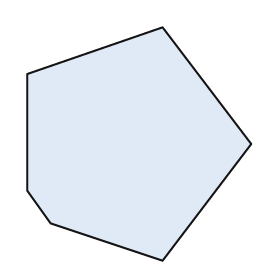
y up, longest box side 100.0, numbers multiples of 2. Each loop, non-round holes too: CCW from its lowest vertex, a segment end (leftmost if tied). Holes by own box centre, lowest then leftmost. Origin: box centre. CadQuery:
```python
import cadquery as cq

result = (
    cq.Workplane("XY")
    .moveTo(10.0, -50.0)
    .lineTo(48.0, 0.0)
    .lineTo(10.0, 50.0)
    .lineTo(-48.0, 30.0)
    .lineTo(-48.0, -20.0)
    .lineTo(-38.0, -34.0)
    .close()
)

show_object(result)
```